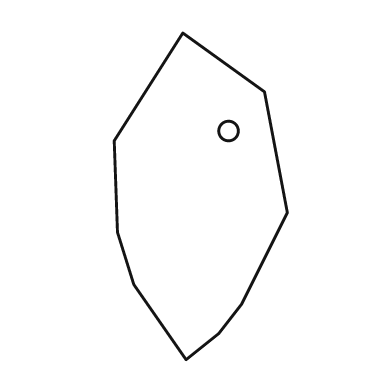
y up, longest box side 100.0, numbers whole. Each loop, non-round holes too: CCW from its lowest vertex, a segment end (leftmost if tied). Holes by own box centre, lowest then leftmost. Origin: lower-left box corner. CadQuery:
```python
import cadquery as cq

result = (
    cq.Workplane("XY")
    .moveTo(22.0, 0.0)
    .lineTo(32.0, 8.0)
    .lineTo(39.0, 17.0)
    .lineTo(53.0, 45.0)
    .lineTo(46.0, 82.0)
    .lineTo(21.0, 100.0)
    .lineTo(0.0, 67.0)
    .lineTo(1.0, 39.0)
    .lineTo(6.0, 23.0)
    .close()
    .moveTo(35.0, 70.0)
    .circle(3.0)
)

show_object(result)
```